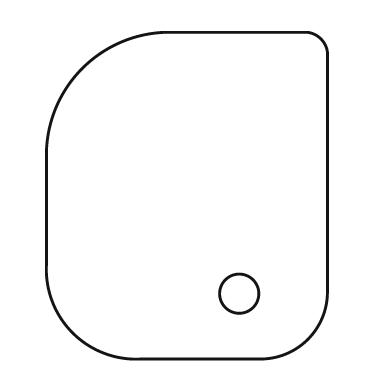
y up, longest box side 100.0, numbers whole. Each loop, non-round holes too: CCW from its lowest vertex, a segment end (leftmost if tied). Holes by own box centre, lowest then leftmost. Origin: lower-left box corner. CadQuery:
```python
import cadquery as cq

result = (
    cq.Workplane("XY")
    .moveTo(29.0, 0.0)
    .lineTo(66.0, 0.0)
    .threePointArc((80.0, 6.0), (86.0, 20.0))
    .lineTo(86.0, 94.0)
    .threePointArc((84.0, 98.0), (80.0, 100.0))
    .lineTo(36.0, 100.0)
    .threePointArc((11.0, 89.0), (0.0, 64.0))
    .lineTo(0.0, 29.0)
    .threePointArc((8.0, 8.0), (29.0, 0.0))
    .close()
    .moveTo(59.0, 20.0)
    .circle(6.0)
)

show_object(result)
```